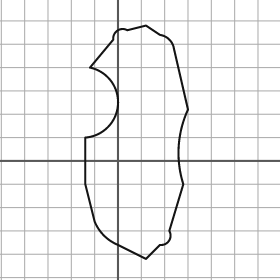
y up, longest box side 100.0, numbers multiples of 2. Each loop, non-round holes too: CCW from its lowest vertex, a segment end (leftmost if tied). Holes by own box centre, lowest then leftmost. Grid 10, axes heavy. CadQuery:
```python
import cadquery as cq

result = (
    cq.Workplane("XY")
    .moveTo(12.0, -42.0)
    .lineTo(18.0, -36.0)
    .threePointArc((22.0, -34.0), (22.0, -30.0))
    .lineTo(28.0, -10.0)
    .threePointArc((26.0, 6.0), (30.0, 22.0))
    .lineTo(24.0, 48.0)
    .threePointArc((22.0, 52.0), (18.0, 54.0))
    .lineTo(12.0, 58.0)
    .lineTo(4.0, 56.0)
    .threePointArc((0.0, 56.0), (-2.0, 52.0))
    .lineTo(-12.0, 40.0)
    .threePointArc((0.0, 24.0), (-14.0, 10.0))
    .lineTo(-14.0, -10.0)
    .lineTo(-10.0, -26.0)
    .threePointArc((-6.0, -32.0), (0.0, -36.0))
    .close()
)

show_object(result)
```